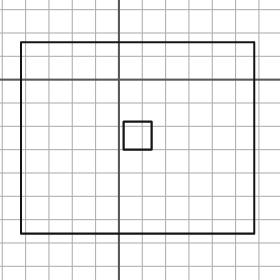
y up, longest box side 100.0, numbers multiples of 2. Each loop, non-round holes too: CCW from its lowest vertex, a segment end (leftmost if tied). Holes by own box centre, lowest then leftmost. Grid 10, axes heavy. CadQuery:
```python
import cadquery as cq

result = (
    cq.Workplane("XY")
    .moveTo(-42.0, -66.0)
    .lineTo(58.0, -66.0)
    .lineTo(58.0, 16.0)
    .lineTo(-42.0, 16.0)
    .close()
    .moveTo(2.0, -30.0)
    .lineTo(14.0, -30.0)
    .lineTo(14.0, -18.0)
    .lineTo(2.0, -18.0)
    .close()
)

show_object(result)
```